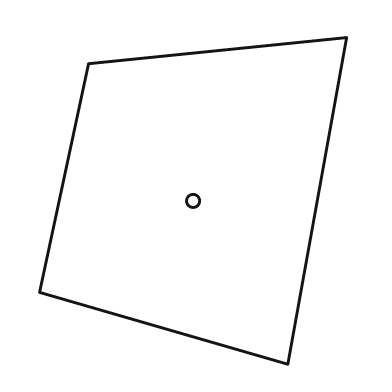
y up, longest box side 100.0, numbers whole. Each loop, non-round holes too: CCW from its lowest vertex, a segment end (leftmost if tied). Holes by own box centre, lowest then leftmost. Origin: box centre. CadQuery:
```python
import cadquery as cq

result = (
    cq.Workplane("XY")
    .moveTo(29.0, -50.0)
    .lineTo(47.0, 50.0)
    .lineTo(-32.0, 42.0)
    .lineTo(-47.0, -28.0)
    .close()
    .moveTo(0.0, 0.0)
    .circle(2.0)
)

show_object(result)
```